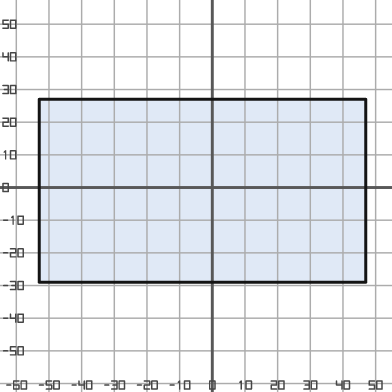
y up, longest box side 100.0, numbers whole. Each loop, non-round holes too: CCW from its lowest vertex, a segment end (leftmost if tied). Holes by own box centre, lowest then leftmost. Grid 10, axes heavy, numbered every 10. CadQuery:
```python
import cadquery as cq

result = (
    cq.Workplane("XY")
    .moveTo(-53.0, -29.0)
    .lineTo(47.0, -29.0)
    .lineTo(47.0, 27.0)
    .lineTo(-53.0, 27.0)
    .close()
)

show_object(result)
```